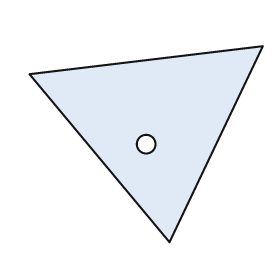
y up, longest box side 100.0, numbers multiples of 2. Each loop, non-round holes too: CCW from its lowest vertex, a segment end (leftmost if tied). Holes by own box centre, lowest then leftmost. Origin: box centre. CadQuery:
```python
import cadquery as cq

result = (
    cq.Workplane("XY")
    .moveTo(10.0, -42.0)
    .lineTo(50.0, 42.0)
    .lineTo(-50.0, 30.0)
    .close()
    .moveTo(0.0, 0.0)
    .circle(4.0)
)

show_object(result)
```